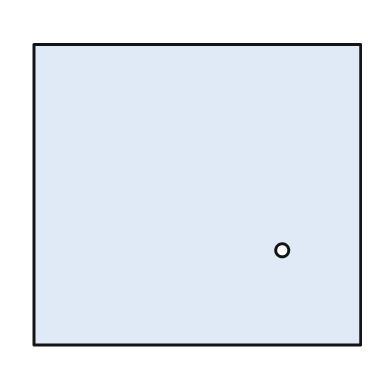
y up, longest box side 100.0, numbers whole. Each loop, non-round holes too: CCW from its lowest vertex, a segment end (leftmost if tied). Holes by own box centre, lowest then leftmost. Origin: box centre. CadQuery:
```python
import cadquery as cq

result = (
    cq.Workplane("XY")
    .moveTo(-50.0, -46.0)
    .lineTo(50.0, -46.0)
    .lineTo(50.0, 46.0)
    .lineTo(-50.0, 46.0)
    .close()
    .moveTo(26.0, -17.0)
    .circle(2.0)
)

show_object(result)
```